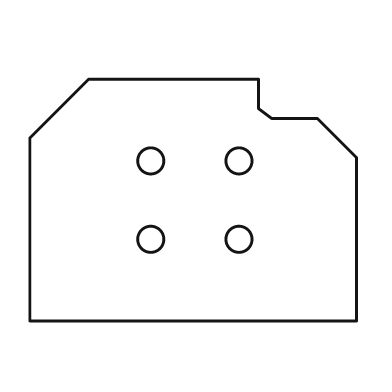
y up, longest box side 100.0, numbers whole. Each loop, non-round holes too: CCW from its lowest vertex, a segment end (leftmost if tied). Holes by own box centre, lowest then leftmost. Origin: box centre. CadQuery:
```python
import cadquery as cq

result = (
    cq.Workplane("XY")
    .moveTo(-50.0, -37.0)
    .lineTo(50.0, -37.0)
    .lineTo(50.0, 13.0)
    .lineTo(38.0, 25.0)
    .lineTo(24.0, 25.0)
    .lineTo(20.0, 28.0)
    .lineTo(20.0, 37.0)
    .lineTo(-32.0, 37.0)
    .lineTo(-50.0, 19.0)
    .close()
    .moveTo(-13.0, -12.0)
    .circle(4.0)
    .moveTo(14.0, -12.0)
    .circle(4.0)
    .moveTo(-13.0, 12.0)
    .circle(4.0)
    .moveTo(14.0, 12.0)
    .circle(4.0)
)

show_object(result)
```